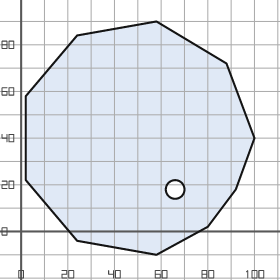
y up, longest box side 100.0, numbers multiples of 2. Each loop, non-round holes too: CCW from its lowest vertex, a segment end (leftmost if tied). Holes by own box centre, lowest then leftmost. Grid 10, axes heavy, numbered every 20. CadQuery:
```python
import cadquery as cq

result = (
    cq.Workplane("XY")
    .moveTo(58.0, -10.0)
    .lineTo(80.0, 2.0)
    .lineTo(92.0, 18.0)
    .lineTo(100.0, 40.0)
    .lineTo(88.0, 72.0)
    .lineTo(58.0, 90.0)
    .lineTo(24.0, 84.0)
    .lineTo(2.0, 58.0)
    .lineTo(2.0, 22.0)
    .lineTo(24.0, -4.0)
    .close()
    .moveTo(66.0, 18.0)
    .circle(4.0)
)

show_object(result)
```